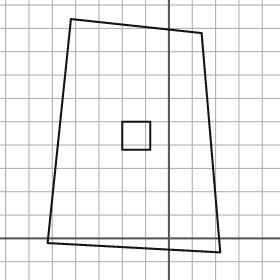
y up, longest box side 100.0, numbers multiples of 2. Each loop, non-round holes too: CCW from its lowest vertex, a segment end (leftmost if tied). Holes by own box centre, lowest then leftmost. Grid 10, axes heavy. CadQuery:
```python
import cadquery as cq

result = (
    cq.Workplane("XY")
    .moveTo(22.0, -6.0)
    .lineTo(14.0, 88.0)
    .lineTo(-42.0, 94.0)
    .lineTo(-52.0, -2.0)
    .close()
    .moveTo(-20.0, 38.0)
    .lineTo(-8.0, 38.0)
    .lineTo(-8.0, 50.0)
    .lineTo(-20.0, 50.0)
    .close()
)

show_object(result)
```